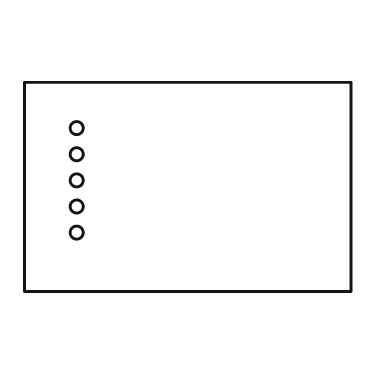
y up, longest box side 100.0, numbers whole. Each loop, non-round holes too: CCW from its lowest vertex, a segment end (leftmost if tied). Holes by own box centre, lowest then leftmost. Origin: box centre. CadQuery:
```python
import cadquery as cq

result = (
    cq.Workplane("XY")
    .moveTo(-50.0, -32.0)
    .lineTo(50.0, -32.0)
    .lineTo(50.0, 32.0)
    .lineTo(-50.0, 32.0)
    .close()
    .moveTo(-34.0, -14.0)
    .circle(2.0)
    .moveTo(-34.0, -6.0)
    .circle(2.0)
    .moveTo(-34.0, 2.0)
    .circle(2.0)
    .moveTo(-34.0, 10.0)
    .circle(2.0)
    .moveTo(-34.0, 18.0)
    .circle(2.0)
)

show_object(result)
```